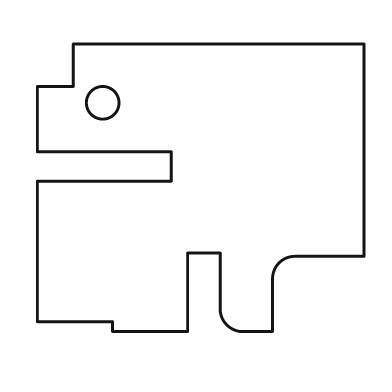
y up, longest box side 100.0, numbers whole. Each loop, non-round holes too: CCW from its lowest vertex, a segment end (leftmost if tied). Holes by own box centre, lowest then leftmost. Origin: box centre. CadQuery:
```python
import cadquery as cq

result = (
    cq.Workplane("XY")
    .moveTo(-27.0, -44.0)
    .lineTo(-4.0, -44.0)
    .lineTo(-4.0, -20.0)
    .lineTo(6.0, -20.0)
    .lineTo(6.0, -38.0)
    .threePointArc((8.0, -42.0), (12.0, -44.0))
    .lineTo(22.0, -44.0)
    .lineTo(22.0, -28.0)
    .threePointArc((24.0, -23.0), (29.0, -21.0))
    .lineTo(50.0, -21.0)
    .lineTo(50.0, 44.0)
    .lineTo(-39.0, 44.0)
    .lineTo(-39.0, 31.0)
    .lineTo(-50.0, 31.0)
    .lineTo(-50.0, 11.0)
    .lineTo(-9.0, 11.0)
    .lineTo(-9.0, 2.0)
    .lineTo(-50.0, 2.0)
    .lineTo(-50.0, -41.0)
    .lineTo(-27.0, -41.0)
    .close()
    .moveTo(-30.0, 26.0)
    .circle(5.0)
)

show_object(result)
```